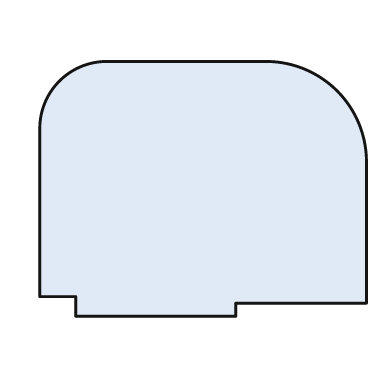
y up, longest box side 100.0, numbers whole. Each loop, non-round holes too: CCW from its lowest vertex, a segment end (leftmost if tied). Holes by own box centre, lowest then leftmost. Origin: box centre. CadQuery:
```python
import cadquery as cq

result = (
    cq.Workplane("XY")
    .moveTo(-39.0, -39.0)
    .lineTo(10.0, -39.0)
    .lineTo(10.0, -35.0)
    .lineTo(50.0, -35.0)
    .lineTo(50.0, 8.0)
    .threePointArc((41.0, 30.0), (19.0, 39.0))
    .lineTo(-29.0, 39.0)
    .threePointArc((-44.0, 33.0), (-50.0, 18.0))
    .lineTo(-50.0, -33.0)
    .lineTo(-39.0, -33.0)
    .close()
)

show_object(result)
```